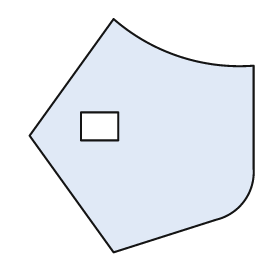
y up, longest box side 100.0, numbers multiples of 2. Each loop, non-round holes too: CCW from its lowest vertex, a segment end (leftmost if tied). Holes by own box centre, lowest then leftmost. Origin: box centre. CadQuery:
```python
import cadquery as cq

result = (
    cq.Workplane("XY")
    .moveTo(-12.0, -50.0)
    .lineTo(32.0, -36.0)
    .threePointArc((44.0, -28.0), (48.0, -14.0))
    .lineTo(48.0, 30.0)
    .threePointArc((16.0, 34.0), (-12.0, 50.0))
    .lineTo(-48.0, 0.0)
    .close()
    .moveTo(-26.0, -2.0)
    .lineTo(-10.0, -2.0)
    .lineTo(-10.0, 10.0)
    .lineTo(-26.0, 10.0)
    .close()
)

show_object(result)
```